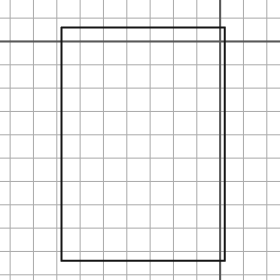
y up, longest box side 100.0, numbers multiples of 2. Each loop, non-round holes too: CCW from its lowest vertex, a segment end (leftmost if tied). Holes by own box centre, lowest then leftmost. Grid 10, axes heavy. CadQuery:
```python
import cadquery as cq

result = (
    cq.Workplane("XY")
    .moveTo(-68.0, -94.0)
    .lineTo(2.0, -94.0)
    .lineTo(2.0, 6.0)
    .lineTo(-68.0, 6.0)
    .close()
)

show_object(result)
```